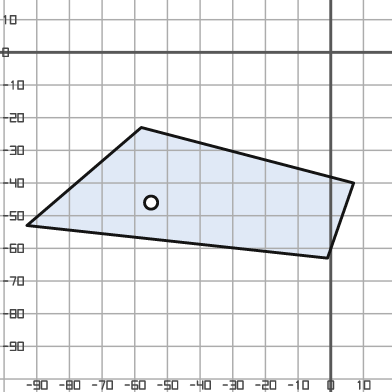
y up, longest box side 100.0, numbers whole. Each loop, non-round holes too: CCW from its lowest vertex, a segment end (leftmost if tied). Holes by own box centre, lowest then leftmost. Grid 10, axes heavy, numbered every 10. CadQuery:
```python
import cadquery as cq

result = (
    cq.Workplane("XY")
    .moveTo(-1.0, -63.0)
    .lineTo(7.0, -40.0)
    .lineTo(-58.0, -23.0)
    .lineTo(-93.0, -53.0)
    .close()
    .moveTo(-55.0, -46.0)
    .circle(2.0)
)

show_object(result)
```